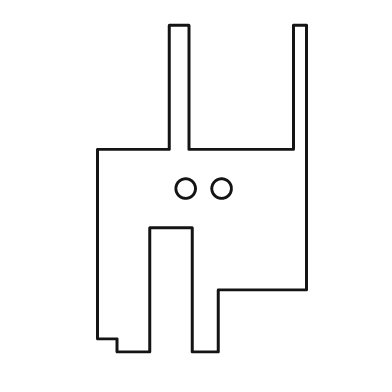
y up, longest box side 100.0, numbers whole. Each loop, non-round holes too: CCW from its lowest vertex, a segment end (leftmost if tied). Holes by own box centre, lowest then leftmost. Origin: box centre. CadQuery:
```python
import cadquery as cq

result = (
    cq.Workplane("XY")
    .moveTo(-26.0, -50.0)
    .lineTo(-16.0, -50.0)
    .lineTo(-16.0, -12.0)
    .lineTo(-3.0, -12.0)
    .lineTo(-3.0, -50.0)
    .lineTo(5.0, -50.0)
    .lineTo(5.0, -31.0)
    .lineTo(32.0, -31.0)
    .lineTo(32.0, 50.0)
    .lineTo(28.0, 50.0)
    .lineTo(28.0, 12.0)
    .lineTo(-4.0, 12.0)
    .lineTo(-4.0, 50.0)
    .lineTo(-10.0, 50.0)
    .lineTo(-10.0, 12.0)
    .lineTo(-32.0, 12.0)
    .lineTo(-32.0, -46.0)
    .lineTo(-26.0, -46.0)
    .close()
    .moveTo(-5.0, 0.0)
    .circle(3.0)
    .moveTo(6.0, 0.0)
    .circle(3.0)
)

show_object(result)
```